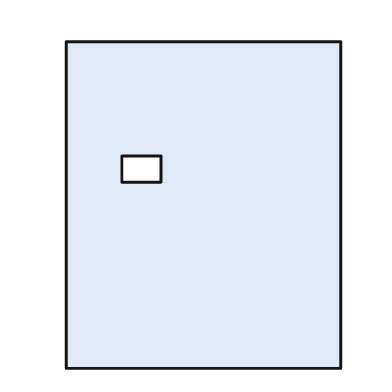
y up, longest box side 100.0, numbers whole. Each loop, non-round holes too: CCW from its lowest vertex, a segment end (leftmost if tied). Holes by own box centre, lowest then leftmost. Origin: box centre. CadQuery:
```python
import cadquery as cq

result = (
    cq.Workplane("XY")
    .moveTo(-42.0, -50.0)
    .lineTo(42.0, -50.0)
    .lineTo(42.0, 50.0)
    .lineTo(-42.0, 50.0)
    .close()
    .moveTo(-25.0, 7.0)
    .lineTo(-13.0, 7.0)
    .lineTo(-13.0, 15.0)
    .lineTo(-25.0, 15.0)
    .close()
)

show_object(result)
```